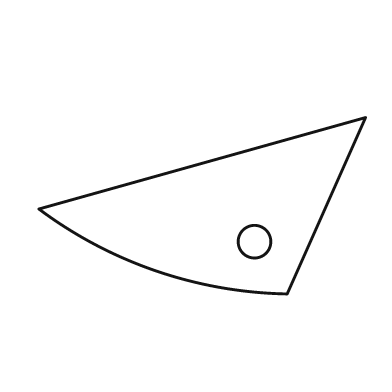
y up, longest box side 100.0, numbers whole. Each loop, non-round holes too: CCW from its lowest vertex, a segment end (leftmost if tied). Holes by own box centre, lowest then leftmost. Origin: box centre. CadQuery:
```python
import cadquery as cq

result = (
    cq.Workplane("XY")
    .moveTo(26.0, -27.0)
    .lineTo(50.0, 27.0)
    .lineTo(-50.0, -1.0)
    .threePointArc((-14.0, -20.0), (26.0, -27.0))
    .close()
    .moveTo(16.0, -11.0)
    .circle(5.0)
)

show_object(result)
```